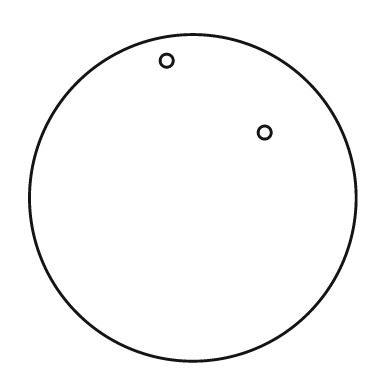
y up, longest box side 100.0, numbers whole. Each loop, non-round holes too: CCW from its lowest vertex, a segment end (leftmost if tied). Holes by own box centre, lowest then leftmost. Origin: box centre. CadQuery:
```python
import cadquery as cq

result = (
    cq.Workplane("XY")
    .moveTo(0.0, 0.0)
    .circle(50.0)
    .moveTo(22.0, 20.0)
    .circle(2.0)
    .moveTo(-8.0, 42.0)
    .circle(2.0)
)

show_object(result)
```